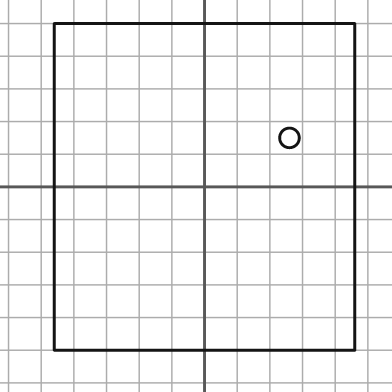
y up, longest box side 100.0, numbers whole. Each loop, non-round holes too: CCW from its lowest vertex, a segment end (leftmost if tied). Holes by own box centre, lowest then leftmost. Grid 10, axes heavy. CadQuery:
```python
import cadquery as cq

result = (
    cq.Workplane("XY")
    .moveTo(-46.0, -50.0)
    .lineTo(46.0, -50.0)
    .lineTo(46.0, 50.0)
    .lineTo(-46.0, 50.0)
    .close()
    .moveTo(26.0, 15.0)
    .circle(3.0)
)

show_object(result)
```